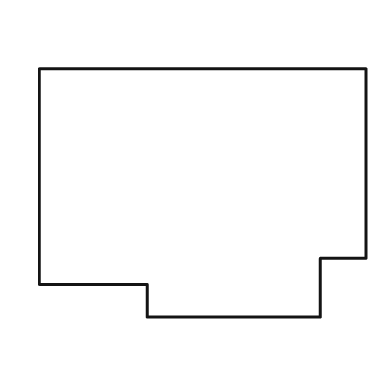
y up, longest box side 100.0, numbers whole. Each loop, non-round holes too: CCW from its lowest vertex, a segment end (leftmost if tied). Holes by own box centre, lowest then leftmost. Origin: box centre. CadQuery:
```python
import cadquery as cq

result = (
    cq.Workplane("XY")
    .moveTo(-17.0, -38.0)
    .lineTo(36.0, -38.0)
    .lineTo(36.0, -20.0)
    .lineTo(50.0, -20.0)
    .lineTo(50.0, 38.0)
    .lineTo(-50.0, 38.0)
    .lineTo(-50.0, -28.0)
    .lineTo(-17.0, -28.0)
    .close()
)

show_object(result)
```